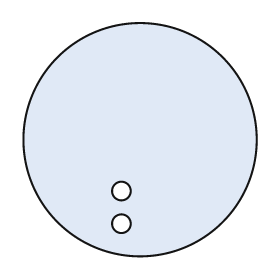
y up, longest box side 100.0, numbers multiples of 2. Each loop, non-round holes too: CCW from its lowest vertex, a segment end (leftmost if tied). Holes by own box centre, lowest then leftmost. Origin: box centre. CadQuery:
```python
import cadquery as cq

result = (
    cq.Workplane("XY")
    .moveTo(0.0, 0.0)
    .circle(50.0)
    .moveTo(-8.0, -36.0)
    .circle(4.0)
    .moveTo(-8.0, -22.0)
    .circle(4.0)
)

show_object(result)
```